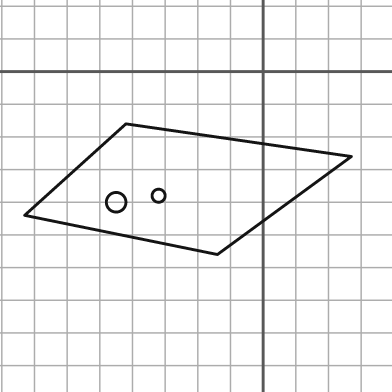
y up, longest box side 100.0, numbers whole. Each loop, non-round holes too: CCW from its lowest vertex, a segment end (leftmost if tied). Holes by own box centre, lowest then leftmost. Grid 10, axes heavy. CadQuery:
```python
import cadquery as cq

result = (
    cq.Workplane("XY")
    .moveTo(-14.0, -56.0)
    .lineTo(27.0, -26.0)
    .lineTo(-42.0, -16.0)
    .lineTo(-73.0, -44.0)
    .close()
    .moveTo(-45.0, -40.0)
    .circle(3.0)
    .moveTo(-32.0, -38.0)
    .circle(2.0)
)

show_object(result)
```